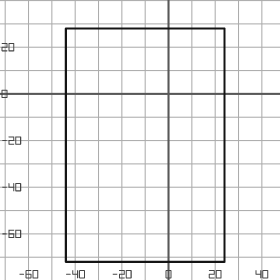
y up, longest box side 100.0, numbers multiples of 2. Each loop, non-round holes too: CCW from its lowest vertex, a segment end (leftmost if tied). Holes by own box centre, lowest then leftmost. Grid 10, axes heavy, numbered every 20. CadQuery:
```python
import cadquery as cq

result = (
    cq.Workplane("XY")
    .moveTo(-44.0, -72.0)
    .lineTo(24.0, -72.0)
    .lineTo(24.0, 28.0)
    .lineTo(-44.0, 28.0)
    .close()
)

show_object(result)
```